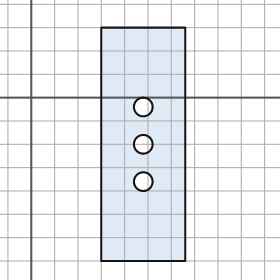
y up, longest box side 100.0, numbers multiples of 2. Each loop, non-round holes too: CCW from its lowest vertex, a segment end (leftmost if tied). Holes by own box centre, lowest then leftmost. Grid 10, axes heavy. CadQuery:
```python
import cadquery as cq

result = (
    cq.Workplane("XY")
    .moveTo(30.0, -70.0)
    .lineTo(66.0, -70.0)
    .lineTo(66.0, 30.0)
    .lineTo(30.0, 30.0)
    .close()
    .moveTo(48.0, -36.0)
    .circle(4.0)
    .moveTo(48.0, -20.0)
    .circle(4.0)
    .moveTo(48.0, -4.0)
    .circle(4.0)
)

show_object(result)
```